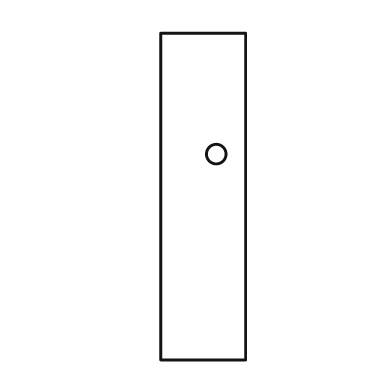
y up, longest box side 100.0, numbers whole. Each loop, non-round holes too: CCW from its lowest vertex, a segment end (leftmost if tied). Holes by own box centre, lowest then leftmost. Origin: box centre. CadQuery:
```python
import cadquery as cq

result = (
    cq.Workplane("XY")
    .moveTo(-13.0, -50.0)
    .lineTo(13.0, -50.0)
    .lineTo(13.0, 50.0)
    .lineTo(-13.0, 50.0)
    .close()
    .moveTo(4.0, 13.0)
    .circle(3.0)
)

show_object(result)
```